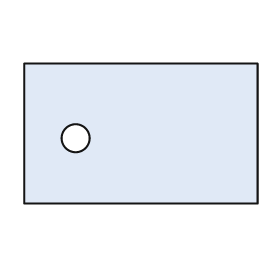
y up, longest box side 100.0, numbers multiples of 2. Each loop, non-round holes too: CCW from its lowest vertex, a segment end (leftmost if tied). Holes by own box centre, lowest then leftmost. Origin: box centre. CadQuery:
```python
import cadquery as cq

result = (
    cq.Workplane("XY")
    .moveTo(-50.0, -30.0)
    .lineTo(50.0, -30.0)
    .lineTo(50.0, 30.0)
    .lineTo(-50.0, 30.0)
    .close()
    .moveTo(-28.0, -2.0)
    .circle(6.0)
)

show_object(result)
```